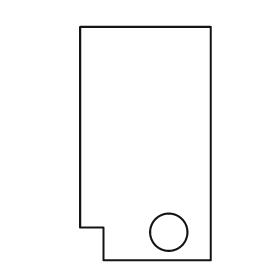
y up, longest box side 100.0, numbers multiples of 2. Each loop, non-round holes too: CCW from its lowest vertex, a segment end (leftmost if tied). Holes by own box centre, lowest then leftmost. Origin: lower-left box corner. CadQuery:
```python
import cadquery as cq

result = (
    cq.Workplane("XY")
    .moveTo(10.0, 0.0)
    .lineTo(56.0, 0.0)
    .lineTo(56.0, 100.0)
    .lineTo(0.0, 100.0)
    .lineTo(0.0, 14.0)
    .lineTo(10.0, 14.0)
    .close()
    .moveTo(38.0, 12.0)
    .circle(8.0)
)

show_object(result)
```